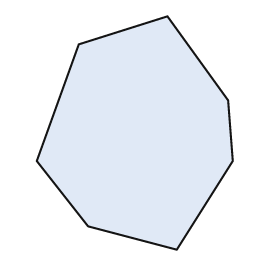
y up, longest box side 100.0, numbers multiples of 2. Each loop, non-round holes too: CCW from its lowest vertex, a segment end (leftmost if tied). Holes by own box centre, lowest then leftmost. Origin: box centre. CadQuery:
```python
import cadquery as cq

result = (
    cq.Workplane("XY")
    .moveTo(18.0, -50.0)
    .lineTo(42.0, -12.0)
    .lineTo(40.0, 14.0)
    .lineTo(14.0, 50.0)
    .lineTo(-24.0, 38.0)
    .lineTo(-42.0, -12.0)
    .lineTo(-20.0, -40.0)
    .close()
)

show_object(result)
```